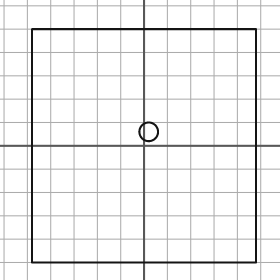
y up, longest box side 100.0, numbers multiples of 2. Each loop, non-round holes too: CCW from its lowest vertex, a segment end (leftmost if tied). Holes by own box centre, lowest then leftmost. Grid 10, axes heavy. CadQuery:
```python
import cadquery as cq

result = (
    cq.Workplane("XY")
    .moveTo(-48.0, -50.0)
    .lineTo(48.0, -50.0)
    .lineTo(48.0, 50.0)
    .lineTo(-48.0, 50.0)
    .close()
    .moveTo(2.0, 6.0)
    .circle(4.0)
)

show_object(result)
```